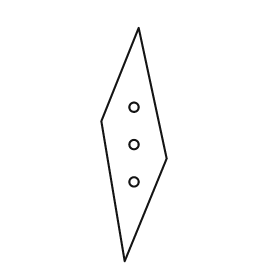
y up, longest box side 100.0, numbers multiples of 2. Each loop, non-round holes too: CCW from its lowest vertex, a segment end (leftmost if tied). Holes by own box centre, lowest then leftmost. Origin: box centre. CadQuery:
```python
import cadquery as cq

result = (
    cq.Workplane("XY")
    .moveTo(-4.0, -50.0)
    .lineTo(14.0, -6.0)
    .lineTo(2.0, 50.0)
    .lineTo(-14.0, 10.0)
    .close()
    .moveTo(0.0, -16.0)
    .circle(2.0)
    .moveTo(0.0, 0.0)
    .circle(2.0)
    .moveTo(0.0, 16.0)
    .circle(2.0)
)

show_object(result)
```